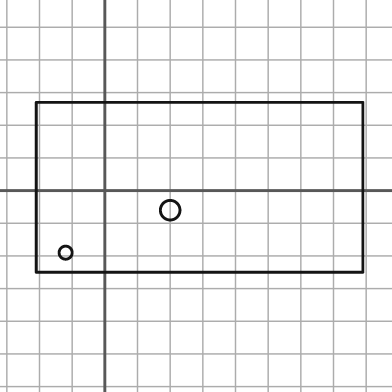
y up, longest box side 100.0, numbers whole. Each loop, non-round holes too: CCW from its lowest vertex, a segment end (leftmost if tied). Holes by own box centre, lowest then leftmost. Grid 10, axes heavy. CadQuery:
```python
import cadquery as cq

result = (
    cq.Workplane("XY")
    .moveTo(-21.0, -25.0)
    .lineTo(79.0, -25.0)
    .lineTo(79.0, 27.0)
    .lineTo(-21.0, 27.0)
    .close()
    .moveTo(-12.0, -19.0)
    .circle(2.0)
    .moveTo(20.0, -6.0)
    .circle(3.0)
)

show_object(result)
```